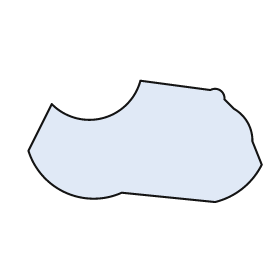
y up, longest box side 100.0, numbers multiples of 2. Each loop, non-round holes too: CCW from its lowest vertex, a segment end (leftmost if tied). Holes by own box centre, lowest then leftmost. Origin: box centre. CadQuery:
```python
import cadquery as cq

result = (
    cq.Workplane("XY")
    .moveTo(30.0, -26.0)
    .threePointArc((42.0, -20.0), (50.0, -10.0))
    .lineTo(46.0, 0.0)
    .threePointArc((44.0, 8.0), (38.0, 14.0))
    .lineTo(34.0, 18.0)
    .threePointArc((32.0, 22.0), (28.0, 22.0))
    .lineTo(-2.0, 26.0)
    .threePointArc((-18.0, 10.0), (-40.0, 16.0))
    .lineTo(-50.0, -4.0)
    .threePointArc((-34.0, -22.0), (-10.0, -22.0))
    .close()
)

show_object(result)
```